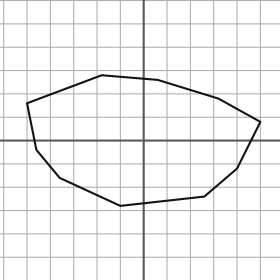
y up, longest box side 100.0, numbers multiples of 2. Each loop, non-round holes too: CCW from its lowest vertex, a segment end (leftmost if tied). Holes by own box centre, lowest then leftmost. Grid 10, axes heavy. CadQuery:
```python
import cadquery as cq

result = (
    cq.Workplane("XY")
    .moveTo(-10.0, -28.0)
    .lineTo(26.0, -24.0)
    .lineTo(40.0, -12.0)
    .lineTo(50.0, 8.0)
    .lineTo(32.0, 18.0)
    .lineTo(6.0, 26.0)
    .lineTo(-18.0, 28.0)
    .lineTo(-50.0, 16.0)
    .lineTo(-46.0, -4.0)
    .lineTo(-36.0, -16.0)
    .close()
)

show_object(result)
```